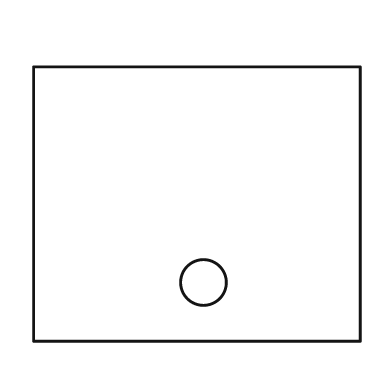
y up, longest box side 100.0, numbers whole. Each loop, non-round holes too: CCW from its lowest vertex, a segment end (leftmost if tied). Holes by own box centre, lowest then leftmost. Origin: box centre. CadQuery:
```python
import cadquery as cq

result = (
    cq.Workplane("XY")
    .moveTo(-50.0, -42.0)
    .lineTo(50.0, -42.0)
    .lineTo(50.0, 42.0)
    .lineTo(-50.0, 42.0)
    .close()
    .moveTo(2.0, -24.0)
    .circle(7.0)
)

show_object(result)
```